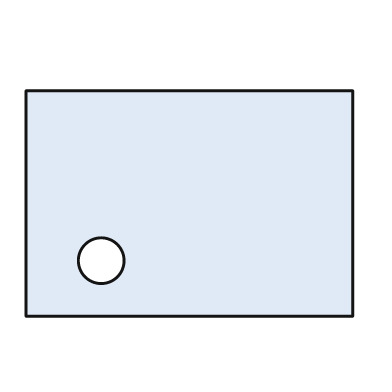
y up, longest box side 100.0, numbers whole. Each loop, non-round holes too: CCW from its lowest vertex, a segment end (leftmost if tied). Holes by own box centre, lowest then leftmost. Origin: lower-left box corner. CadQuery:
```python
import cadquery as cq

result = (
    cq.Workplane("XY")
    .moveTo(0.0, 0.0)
    .lineTo(100.0, 0.0)
    .lineTo(100.0, 69.0)
    .lineTo(0.0, 69.0)
    .close()
    .moveTo(23.0, 17.0)
    .circle(7.0)
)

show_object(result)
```